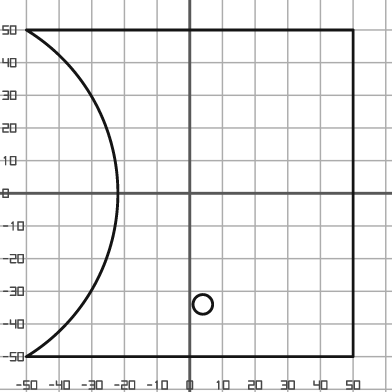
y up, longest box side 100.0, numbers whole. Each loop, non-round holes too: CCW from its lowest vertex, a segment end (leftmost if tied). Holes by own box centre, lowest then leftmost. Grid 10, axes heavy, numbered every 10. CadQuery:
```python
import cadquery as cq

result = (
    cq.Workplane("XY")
    .moveTo(-50.0, -50.0)
    .lineTo(50.0, -50.0)
    .lineTo(50.0, 50.0)
    .lineTo(-50.0, 50.0)
    .threePointArc((-22.0, 0.0), (-50.0, -50.0))
    .close()
    .moveTo(4.0, -34.0)
    .circle(3.0)
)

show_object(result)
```